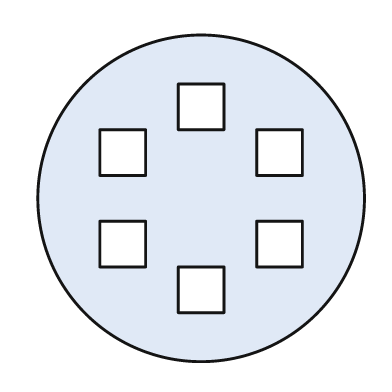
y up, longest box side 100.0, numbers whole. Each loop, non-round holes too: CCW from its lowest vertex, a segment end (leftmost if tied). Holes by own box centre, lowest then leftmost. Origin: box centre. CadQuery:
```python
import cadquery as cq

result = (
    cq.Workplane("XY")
    .moveTo(0.0, 0.0)
    .circle(50.0)
    .moveTo(-7.0, -35.0)
    .lineTo(7.0, -35.0)
    .lineTo(7.0, -21.0)
    .lineTo(-7.0, -21.0)
    .close()
    .moveTo(-31.0, -21.0)
    .lineTo(-17.0, -21.0)
    .lineTo(-17.0, -7.0)
    .lineTo(-31.0, -7.0)
    .close()
    .moveTo(17.0, -21.0)
    .lineTo(31.0, -21.0)
    .lineTo(31.0, -7.0)
    .lineTo(17.0, -7.0)
    .close()
    .moveTo(-31.0, 7.0)
    .lineTo(-17.0, 7.0)
    .lineTo(-17.0, 21.0)
    .lineTo(-31.0, 21.0)
    .close()
    .moveTo(17.0, 7.0)
    .lineTo(31.0, 7.0)
    .lineTo(31.0, 21.0)
    .lineTo(17.0, 21.0)
    .close()
    .moveTo(-7.0, 21.0)
    .lineTo(7.0, 21.0)
    .lineTo(7.0, 35.0)
    .lineTo(-7.0, 35.0)
    .close()
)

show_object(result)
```